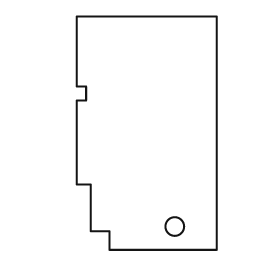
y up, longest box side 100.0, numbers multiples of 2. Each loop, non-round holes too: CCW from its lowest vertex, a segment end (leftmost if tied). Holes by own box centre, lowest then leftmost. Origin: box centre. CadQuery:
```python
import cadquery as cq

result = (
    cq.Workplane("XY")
    .moveTo(-16.0, -50.0)
    .lineTo(30.0, -50.0)
    .lineTo(30.0, 50.0)
    .lineTo(-30.0, 50.0)
    .lineTo(-30.0, 20.0)
    .lineTo(-26.0, 20.0)
    .lineTo(-26.0, 14.0)
    .lineTo(-30.0, 14.0)
    .lineTo(-30.0, -22.0)
    .lineTo(-24.0, -22.0)
    .lineTo(-24.0, -42.0)
    .lineTo(-16.0, -42.0)
    .close()
    .moveTo(12.0, -40.0)
    .circle(4.0)
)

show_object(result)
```